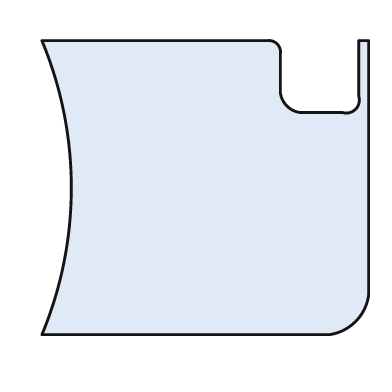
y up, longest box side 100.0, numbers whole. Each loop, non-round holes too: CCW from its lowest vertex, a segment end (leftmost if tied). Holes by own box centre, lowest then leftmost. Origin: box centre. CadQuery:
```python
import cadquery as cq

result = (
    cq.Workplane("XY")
    .moveTo(-50.0, -45.0)
    .lineTo(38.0, -45.0)
    .threePointArc((46.0, -41.0), (50.0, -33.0))
    .lineTo(50.0, 45.0)
    .lineTo(47.0, 45.0)
    .lineTo(47.0, 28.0)
    .threePointArc((46.0, 24.0), (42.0, 23.0))
    .lineTo(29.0, 23.0)
    .threePointArc((25.0, 25.0), (23.0, 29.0))
    .lineTo(23.0, 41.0)
    .threePointArc((22.0, 44.0), (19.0, 45.0))
    .lineTo(-50.0, 45.0)
    .threePointArc((-41.0, 0.0), (-50.0, -45.0))
    .close()
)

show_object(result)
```